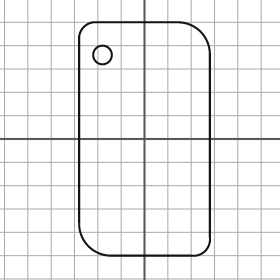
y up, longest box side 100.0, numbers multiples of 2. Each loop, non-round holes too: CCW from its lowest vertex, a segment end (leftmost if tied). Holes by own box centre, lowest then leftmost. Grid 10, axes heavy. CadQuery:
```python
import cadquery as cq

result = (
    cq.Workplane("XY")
    .moveTo(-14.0, -50.0)
    .lineTo(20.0, -50.0)
    .threePointArc((26.0, -48.0), (28.0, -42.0))
    .lineTo(28.0, 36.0)
    .threePointArc((24.0, 46.0), (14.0, 50.0))
    .lineTo(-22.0, 50.0)
    .threePointArc((-26.0, 48.0), (-28.0, 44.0))
    .lineTo(-28.0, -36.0)
    .threePointArc((-24.0, -46.0), (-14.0, -50.0))
    .close()
    .moveTo(-18.0, 36.0)
    .circle(4.0)
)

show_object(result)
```